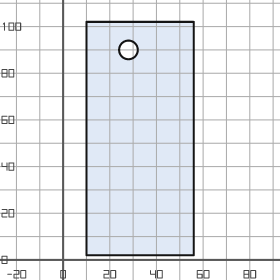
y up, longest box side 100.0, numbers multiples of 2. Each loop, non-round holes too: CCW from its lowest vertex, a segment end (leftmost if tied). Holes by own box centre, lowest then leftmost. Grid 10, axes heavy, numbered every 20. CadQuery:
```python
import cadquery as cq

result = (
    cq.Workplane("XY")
    .moveTo(10.0, 2.0)
    .lineTo(56.0, 2.0)
    .lineTo(56.0, 102.0)
    .lineTo(10.0, 102.0)
    .close()
    .moveTo(28.0, 90.0)
    .circle(4.0)
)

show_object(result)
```